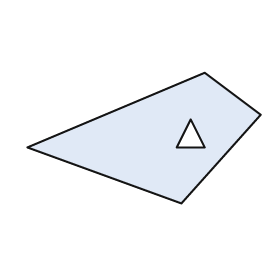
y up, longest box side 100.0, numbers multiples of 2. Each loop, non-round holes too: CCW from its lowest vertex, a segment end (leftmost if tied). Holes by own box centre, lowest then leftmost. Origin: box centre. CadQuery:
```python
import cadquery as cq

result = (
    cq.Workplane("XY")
    .moveTo(16.0, -28.0)
    .lineTo(50.0, 10.0)
    .lineTo(26.0, 28.0)
    .lineTo(-50.0, -4.0)
    .close()
    .moveTo(14.0, -4.0)
    .lineTo(26.0, -4.0)
    .lineTo(20.0, 8.0)
    .close()
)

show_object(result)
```